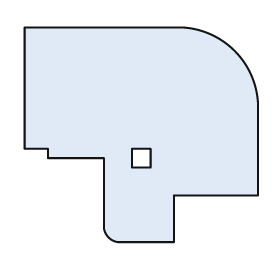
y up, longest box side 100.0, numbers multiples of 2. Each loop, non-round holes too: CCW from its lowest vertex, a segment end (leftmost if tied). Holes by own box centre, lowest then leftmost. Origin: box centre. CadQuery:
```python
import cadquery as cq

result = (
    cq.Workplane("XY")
    .moveTo(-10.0, -46.0)
    .lineTo(14.0, -46.0)
    .lineTo(14.0, -26.0)
    .lineTo(50.0, -26.0)
    .lineTo(50.0, 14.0)
    .threePointArc((40.0, 36.0), (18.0, 46.0))
    .lineTo(-50.0, 46.0)
    .lineTo(-50.0, -6.0)
    .lineTo(-40.0, -6.0)
    .lineTo(-40.0, -10.0)
    .lineTo(-16.0, -10.0)
    .lineTo(-16.0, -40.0)
    .threePointArc((-14.0, -44.0), (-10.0, -46.0))
    .close()
    .moveTo(-4.0, -14.0)
    .lineTo(4.0, -14.0)
    .lineTo(4.0, -6.0)
    .lineTo(-4.0, -6.0)
    .close()
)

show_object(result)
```